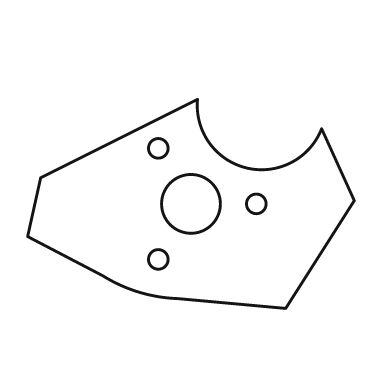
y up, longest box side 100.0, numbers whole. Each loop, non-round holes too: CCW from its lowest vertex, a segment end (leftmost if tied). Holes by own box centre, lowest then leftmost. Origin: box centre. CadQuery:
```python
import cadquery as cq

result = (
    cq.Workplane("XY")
    .moveTo(29.0, -32.0)
    .lineTo(50.0, 1.0)
    .lineTo(40.0, 23.0)
    .threePointArc((17.0, 11.0), (2.0, 32.0))
    .lineTo(-46.0, 8.0)
    .lineTo(-50.0, -10.0)
    .lineTo(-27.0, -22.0)
    .threePointArc((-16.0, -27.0), (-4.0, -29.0))
    .close()
    .moveTo(-10.0, -17.0)
    .circle(3.0)
    .moveTo(0.0, 0.0)
    .circle(9.0)
    .moveTo(20.0, 0.0)
    .circle(3.0)
    .moveTo(-10.0, 17.0)
    .circle(3.0)
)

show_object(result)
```